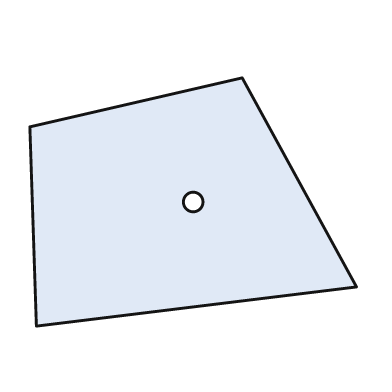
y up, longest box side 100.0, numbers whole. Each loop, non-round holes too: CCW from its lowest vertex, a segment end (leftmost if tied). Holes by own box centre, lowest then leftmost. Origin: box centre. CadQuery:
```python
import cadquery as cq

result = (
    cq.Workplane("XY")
    .moveTo(-48.0, -38.0)
    .lineTo(50.0, -26.0)
    .lineTo(15.0, 38.0)
    .lineTo(-50.0, 23.0)
    .close()
    .moveTo(0.0, 0.0)
    .circle(3.0)
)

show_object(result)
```